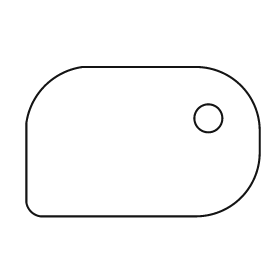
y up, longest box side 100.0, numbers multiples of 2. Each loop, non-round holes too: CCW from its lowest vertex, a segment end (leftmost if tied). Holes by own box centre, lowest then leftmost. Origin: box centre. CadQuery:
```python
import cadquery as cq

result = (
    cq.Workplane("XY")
    .moveTo(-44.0, -32.0)
    .lineTo(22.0, -32.0)
    .threePointArc((42.0, -24.0), (50.0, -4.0))
    .lineTo(50.0, 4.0)
    .threePointArc((42.0, 24.0), (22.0, 32.0))
    .lineTo(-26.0, 32.0)
    .threePointArc((-42.0, 24.0), (-50.0, 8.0))
    .lineTo(-50.0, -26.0)
    .threePointArc((-48.0, -30.0), (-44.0, -32.0))
    .close()
    .moveTo(28.0, 10.0)
    .circle(6.0)
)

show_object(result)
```